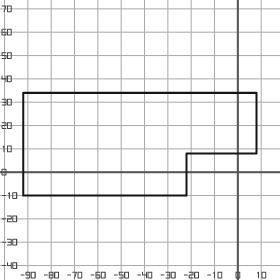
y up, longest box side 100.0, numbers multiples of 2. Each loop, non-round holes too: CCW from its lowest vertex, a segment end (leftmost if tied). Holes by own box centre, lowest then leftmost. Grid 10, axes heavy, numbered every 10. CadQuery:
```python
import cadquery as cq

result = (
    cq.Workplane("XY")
    .moveTo(-92.0, -10.0)
    .lineTo(-22.0, -10.0)
    .lineTo(-22.0, 8.0)
    .lineTo(8.0, 8.0)
    .lineTo(8.0, 34.0)
    .lineTo(-92.0, 34.0)
    .close()
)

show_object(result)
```